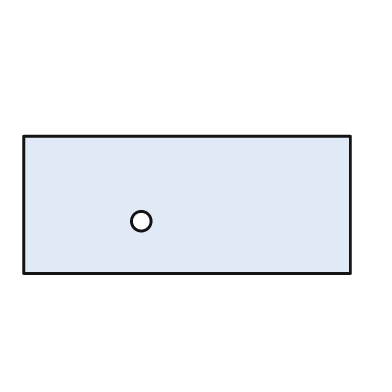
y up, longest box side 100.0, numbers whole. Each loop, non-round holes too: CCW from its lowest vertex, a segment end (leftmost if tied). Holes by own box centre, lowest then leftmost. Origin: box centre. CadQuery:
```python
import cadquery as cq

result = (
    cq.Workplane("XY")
    .moveTo(-50.0, -21.0)
    .lineTo(50.0, -21.0)
    .lineTo(50.0, 21.0)
    .lineTo(-50.0, 21.0)
    .close()
    .moveTo(-14.0, -5.0)
    .circle(3.0)
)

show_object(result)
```